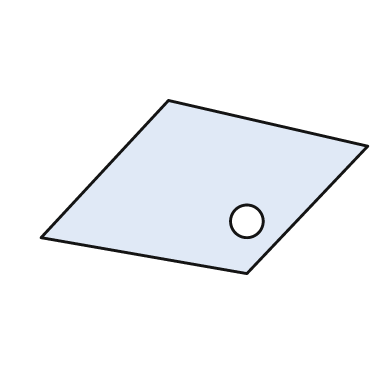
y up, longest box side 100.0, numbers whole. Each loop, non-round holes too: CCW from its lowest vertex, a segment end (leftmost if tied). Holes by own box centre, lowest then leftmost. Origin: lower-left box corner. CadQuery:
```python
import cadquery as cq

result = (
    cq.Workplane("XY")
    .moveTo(63.0, 0.0)
    .lineTo(100.0, 39.0)
    .lineTo(39.0, 53.0)
    .lineTo(0.0, 11.0)
    .close()
    .moveTo(63.0, 16.0)
    .circle(5.0)
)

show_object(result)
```